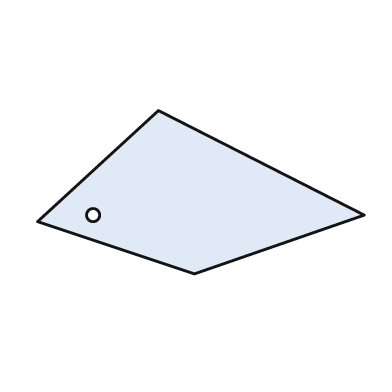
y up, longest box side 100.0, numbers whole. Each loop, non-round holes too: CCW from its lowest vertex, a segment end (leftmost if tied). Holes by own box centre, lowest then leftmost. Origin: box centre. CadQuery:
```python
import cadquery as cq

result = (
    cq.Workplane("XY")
    .moveTo(-2.0, -25.0)
    .lineTo(50.0, -7.0)
    .lineTo(-13.0, 25.0)
    .lineTo(-50.0, -9.0)
    .close()
    .moveTo(-33.0, -7.0)
    .circle(2.0)
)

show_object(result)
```